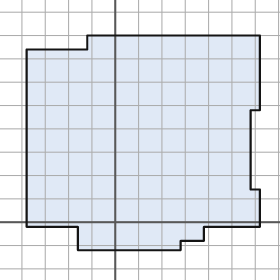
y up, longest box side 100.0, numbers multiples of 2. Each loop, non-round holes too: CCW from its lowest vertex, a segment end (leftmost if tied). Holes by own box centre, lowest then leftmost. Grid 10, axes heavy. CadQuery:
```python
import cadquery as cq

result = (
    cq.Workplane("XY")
    .moveTo(-16.0, -12.0)
    .lineTo(28.0, -12.0)
    .lineTo(28.0, -8.0)
    .lineTo(38.0, -8.0)
    .lineTo(38.0, -2.0)
    .lineTo(62.0, -2.0)
    .lineTo(62.0, 14.0)
    .lineTo(58.0, 14.0)
    .lineTo(58.0, 48.0)
    .lineTo(62.0, 48.0)
    .lineTo(62.0, 80.0)
    .lineTo(-12.0, 80.0)
    .lineTo(-12.0, 74.0)
    .lineTo(-38.0, 74.0)
    .lineTo(-38.0, -2.0)
    .lineTo(-16.0, -2.0)
    .close()
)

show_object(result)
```